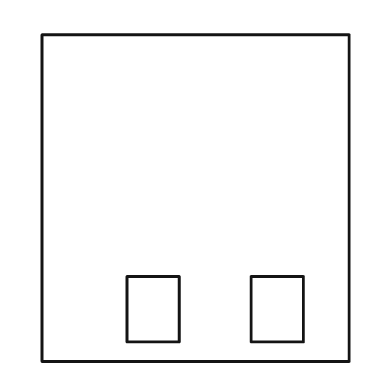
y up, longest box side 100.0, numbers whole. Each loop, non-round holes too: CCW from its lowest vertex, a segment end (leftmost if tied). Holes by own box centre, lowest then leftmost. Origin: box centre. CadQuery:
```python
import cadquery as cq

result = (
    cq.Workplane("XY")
    .moveTo(-47.0, -50.0)
    .lineTo(47.0, -50.0)
    .lineTo(47.0, 50.0)
    .lineTo(-47.0, 50.0)
    .close()
    .moveTo(-21.0, -44.0)
    .lineTo(-5.0, -44.0)
    .lineTo(-5.0, -24.0)
    .lineTo(-21.0, -24.0)
    .close()
    .moveTo(17.0, -44.0)
    .lineTo(33.0, -44.0)
    .lineTo(33.0, -24.0)
    .lineTo(17.0, -24.0)
    .close()
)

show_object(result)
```